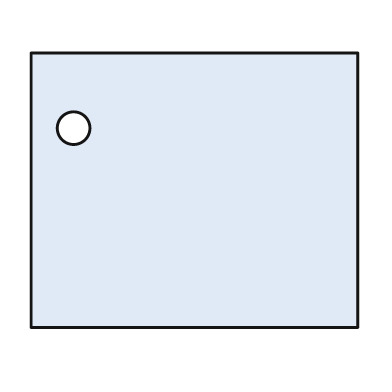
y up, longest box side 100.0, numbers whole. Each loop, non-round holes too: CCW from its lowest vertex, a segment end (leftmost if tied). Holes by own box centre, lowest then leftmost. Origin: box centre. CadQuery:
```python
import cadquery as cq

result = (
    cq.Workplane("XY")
    .moveTo(-50.0, -42.0)
    .lineTo(50.0, -42.0)
    .lineTo(50.0, 42.0)
    .lineTo(-50.0, 42.0)
    .close()
    .moveTo(-37.0, 19.0)
    .circle(5.0)
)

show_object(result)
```